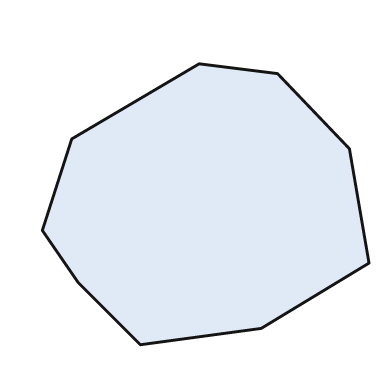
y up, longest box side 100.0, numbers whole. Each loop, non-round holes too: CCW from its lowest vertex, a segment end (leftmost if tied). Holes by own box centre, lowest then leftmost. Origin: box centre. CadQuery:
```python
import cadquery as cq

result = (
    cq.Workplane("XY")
    .moveTo(-20.0, -43.0)
    .lineTo(17.0, -38.0)
    .lineTo(50.0, -18.0)
    .lineTo(44.0, 17.0)
    .lineTo(22.0, 40.0)
    .lineTo(-2.0, 43.0)
    .lineTo(-41.0, 20.0)
    .lineTo(-50.0, -8.0)
    .lineTo(-39.0, -24.0)
    .close()
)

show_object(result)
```